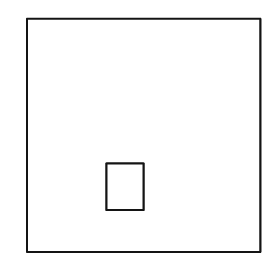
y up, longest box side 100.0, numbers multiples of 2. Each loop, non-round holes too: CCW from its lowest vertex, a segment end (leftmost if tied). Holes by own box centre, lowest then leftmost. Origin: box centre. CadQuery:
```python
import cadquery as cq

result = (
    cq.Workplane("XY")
    .moveTo(-50.0, -50.0)
    .lineTo(50.0, -50.0)
    .lineTo(50.0, 50.0)
    .lineTo(-50.0, 50.0)
    .close()
    .moveTo(-16.0, -32.0)
    .lineTo(0.0, -32.0)
    .lineTo(0.0, -12.0)
    .lineTo(-16.0, -12.0)
    .close()
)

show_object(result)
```